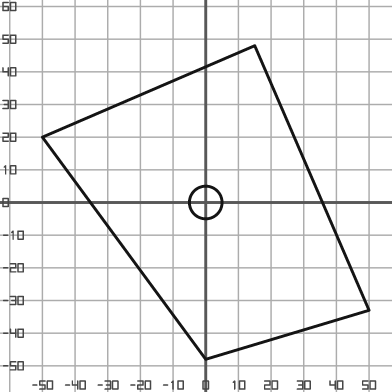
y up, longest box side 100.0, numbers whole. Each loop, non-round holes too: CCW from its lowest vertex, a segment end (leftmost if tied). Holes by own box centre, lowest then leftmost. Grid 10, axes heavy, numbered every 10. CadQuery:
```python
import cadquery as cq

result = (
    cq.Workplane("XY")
    .moveTo(0.0, -48.0)
    .lineTo(50.0, -33.0)
    .lineTo(15.0, 48.0)
    .lineTo(-50.0, 20.0)
    .close()
    .moveTo(0.0, 0.0)
    .circle(5.0)
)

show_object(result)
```